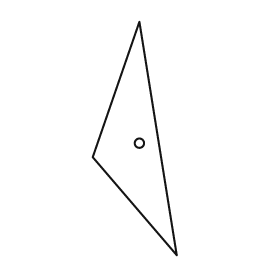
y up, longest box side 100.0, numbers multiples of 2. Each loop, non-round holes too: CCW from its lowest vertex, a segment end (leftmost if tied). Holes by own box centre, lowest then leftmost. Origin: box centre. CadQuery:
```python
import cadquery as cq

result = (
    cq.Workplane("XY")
    .moveTo(18.0, -50.0)
    .lineTo(2.0, 50.0)
    .lineTo(-18.0, -8.0)
    .close()
    .moveTo(2.0, -2.0)
    .circle(2.0)
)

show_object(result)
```